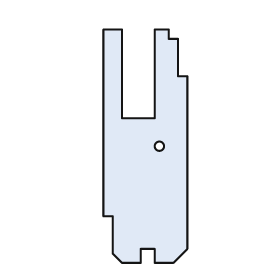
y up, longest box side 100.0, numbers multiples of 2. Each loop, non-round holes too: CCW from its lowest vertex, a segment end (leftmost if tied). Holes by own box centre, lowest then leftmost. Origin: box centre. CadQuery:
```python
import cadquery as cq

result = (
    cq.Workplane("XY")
    .moveTo(-10.0, -50.0)
    .lineTo(-2.0, -50.0)
    .lineTo(-2.0, -44.0)
    .lineTo(4.0, -44.0)
    .lineTo(4.0, -50.0)
    .lineTo(12.0, -50.0)
    .lineTo(18.0, -44.0)
    .lineTo(18.0, 30.0)
    .lineTo(14.0, 30.0)
    .lineTo(14.0, 46.0)
    .lineTo(10.0, 46.0)
    .lineTo(10.0, 50.0)
    .lineTo(4.0, 50.0)
    .lineTo(4.0, 12.0)
    .lineTo(-10.0, 12.0)
    .lineTo(-10.0, 50.0)
    .lineTo(-18.0, 50.0)
    .lineTo(-18.0, -30.0)
    .lineTo(-14.0, -30.0)
    .lineTo(-14.0, -46.0)
    .close()
    .moveTo(6.0, 0.0)
    .circle(2.0)
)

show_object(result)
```